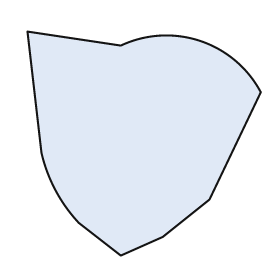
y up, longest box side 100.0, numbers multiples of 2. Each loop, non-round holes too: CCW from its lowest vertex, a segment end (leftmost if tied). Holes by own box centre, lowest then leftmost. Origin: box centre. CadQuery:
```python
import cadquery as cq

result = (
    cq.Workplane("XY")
    .moveTo(-10.0, -48.0)
    .lineTo(8.0, -40.0)
    .lineTo(28.0, -24.0)
    .lineTo(50.0, 22.0)
    .threePointArc((24.0, 44.0), (-10.0, 42.0))
    .lineTo(-50.0, 48.0)
    .lineTo(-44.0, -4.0)
    .threePointArc((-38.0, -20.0), (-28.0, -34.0))
    .close()
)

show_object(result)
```